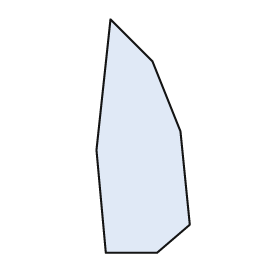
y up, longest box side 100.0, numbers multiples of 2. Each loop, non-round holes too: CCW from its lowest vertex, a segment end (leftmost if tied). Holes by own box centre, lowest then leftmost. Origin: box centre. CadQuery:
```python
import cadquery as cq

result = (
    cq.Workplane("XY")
    .moveTo(-16.0, -50.0)
    .lineTo(6.0, -50.0)
    .lineTo(20.0, -38.0)
    .lineTo(16.0, 2.0)
    .lineTo(4.0, 32.0)
    .lineTo(-14.0, 50.0)
    .lineTo(-20.0, -6.0)
    .close()
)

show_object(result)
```